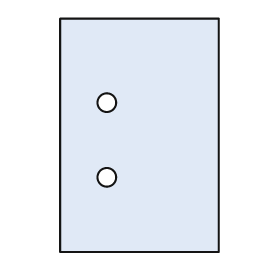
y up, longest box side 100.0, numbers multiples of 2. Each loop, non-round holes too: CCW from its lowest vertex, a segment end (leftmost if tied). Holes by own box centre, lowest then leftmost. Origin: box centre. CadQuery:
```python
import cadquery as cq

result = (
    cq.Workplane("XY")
    .moveTo(-34.0, -50.0)
    .lineTo(34.0, -50.0)
    .lineTo(34.0, 50.0)
    .lineTo(-34.0, 50.0)
    .close()
    .moveTo(-14.0, -18.0)
    .circle(4.0)
    .moveTo(-14.0, 14.0)
    .circle(4.0)
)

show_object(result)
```